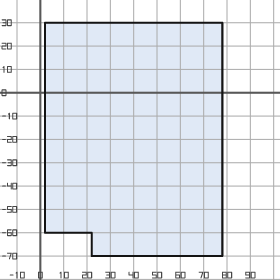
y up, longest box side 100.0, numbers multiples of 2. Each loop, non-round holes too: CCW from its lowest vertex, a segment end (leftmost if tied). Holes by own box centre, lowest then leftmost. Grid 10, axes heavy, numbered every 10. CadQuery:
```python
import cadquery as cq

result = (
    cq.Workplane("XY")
    .moveTo(22.0, -70.0)
    .lineTo(78.0, -70.0)
    .lineTo(78.0, 30.0)
    .lineTo(2.0, 30.0)
    .lineTo(2.0, -60.0)
    .lineTo(22.0, -60.0)
    .close()
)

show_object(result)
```